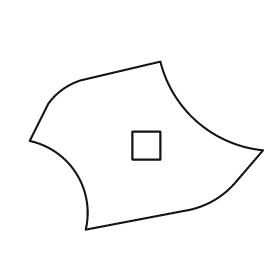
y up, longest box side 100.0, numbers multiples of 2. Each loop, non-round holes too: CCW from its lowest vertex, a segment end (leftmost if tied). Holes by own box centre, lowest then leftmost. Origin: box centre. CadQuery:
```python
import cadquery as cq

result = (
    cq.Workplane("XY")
    .moveTo(-26.0, -36.0)
    .lineTo(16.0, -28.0)
    .threePointArc((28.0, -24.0), (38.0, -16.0))
    .lineTo(50.0, -2.0)
    .threePointArc((22.0, 10.0), (6.0, 36.0))
    .lineTo(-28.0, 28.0)
    .threePointArc((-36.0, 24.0), (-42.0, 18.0))
    .lineTo(-50.0, 2.0)
    .threePointArc((-30.0, -12.0), (-26.0, -36.0))
    .close()
    .moveTo(-6.0, -6.0)
    .lineTo(6.0, -6.0)
    .lineTo(6.0, 6.0)
    .lineTo(-6.0, 6.0)
    .close()
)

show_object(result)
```